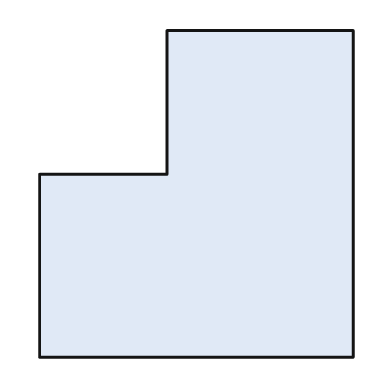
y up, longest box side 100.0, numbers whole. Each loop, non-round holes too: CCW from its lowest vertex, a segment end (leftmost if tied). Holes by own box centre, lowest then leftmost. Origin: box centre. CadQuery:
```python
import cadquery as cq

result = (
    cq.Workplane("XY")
    .moveTo(-48.0, -50.0)
    .lineTo(48.0, -50.0)
    .lineTo(48.0, 50.0)
    .lineTo(-9.0, 50.0)
    .lineTo(-9.0, 6.0)
    .lineTo(-48.0, 6.0)
    .close()
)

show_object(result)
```